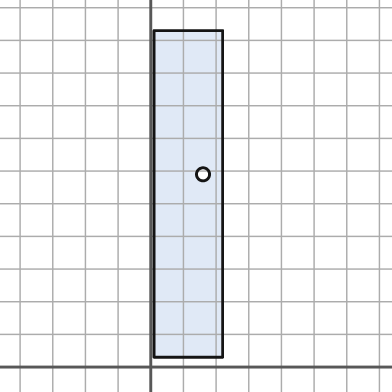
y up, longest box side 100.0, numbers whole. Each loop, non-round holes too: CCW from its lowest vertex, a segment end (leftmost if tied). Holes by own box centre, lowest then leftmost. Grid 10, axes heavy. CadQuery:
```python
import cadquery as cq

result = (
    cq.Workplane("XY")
    .moveTo(1.0, 3.0)
    .lineTo(22.0, 3.0)
    .lineTo(22.0, 103.0)
    .lineTo(1.0, 103.0)
    .close()
    .moveTo(16.0, 59.0)
    .circle(2.0)
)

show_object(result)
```